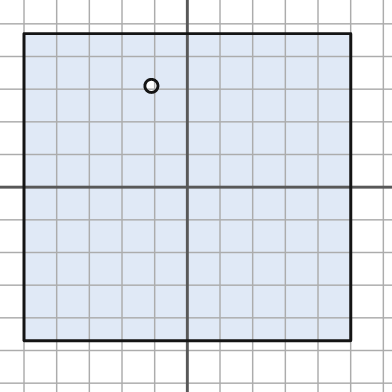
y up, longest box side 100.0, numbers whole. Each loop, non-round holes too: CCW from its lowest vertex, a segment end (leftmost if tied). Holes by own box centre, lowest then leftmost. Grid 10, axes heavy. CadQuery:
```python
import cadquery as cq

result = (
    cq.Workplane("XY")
    .moveTo(-50.0, -47.0)
    .lineTo(50.0, -47.0)
    .lineTo(50.0, 47.0)
    .lineTo(-50.0, 47.0)
    .close()
    .moveTo(-11.0, 31.0)
    .circle(2.0)
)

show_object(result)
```